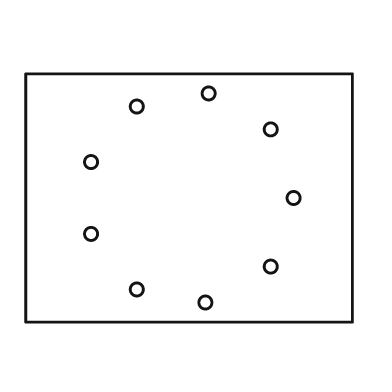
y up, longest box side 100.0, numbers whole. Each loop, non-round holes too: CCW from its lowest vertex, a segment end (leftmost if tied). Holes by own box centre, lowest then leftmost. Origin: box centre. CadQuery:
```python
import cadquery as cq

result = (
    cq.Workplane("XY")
    .moveTo(-50.0, -38.0)
    .lineTo(50.0, -38.0)
    .lineTo(50.0, 38.0)
    .lineTo(-50.0, 38.0)
    .close()
    .moveTo(5.0, -32.0)
    .circle(2.0)
    .moveTo(-16.0, -28.0)
    .circle(2.0)
    .moveTo(25.0, -21.0)
    .circle(2.0)
    .moveTo(-30.0, -11.0)
    .circle(2.0)
    .moveTo(32.0, 0.0)
    .circle(2.0)
    .moveTo(-30.0, 11.0)
    .circle(2.0)
    .moveTo(25.0, 21.0)
    .circle(2.0)
    .moveTo(-16.0, 28.0)
    .circle(2.0)
    .moveTo(6.0, 32.0)
    .circle(2.0)
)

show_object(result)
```